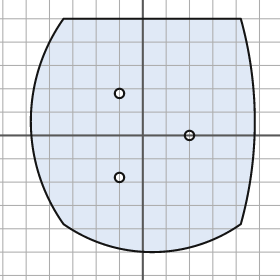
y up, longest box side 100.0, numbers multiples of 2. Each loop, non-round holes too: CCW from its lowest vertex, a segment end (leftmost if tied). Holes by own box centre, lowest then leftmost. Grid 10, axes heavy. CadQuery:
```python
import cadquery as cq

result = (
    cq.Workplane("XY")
    .moveTo(-34.0, -38.0)
    .threePointArc((4.0, -50.0), (42.0, -38.0))
    .threePointArc((48.0, 6.0), (42.0, 50.0))
    .lineTo(-34.0, 50.0)
    .threePointArc((-48.0, 6.0), (-34.0, -38.0))
    .close()
    .moveTo(-10.0, -18.0)
    .circle(2.0)
    .moveTo(20.0, 0.0)
    .circle(2.0)
    .moveTo(-10.0, 18.0)
    .circle(2.0)
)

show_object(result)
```